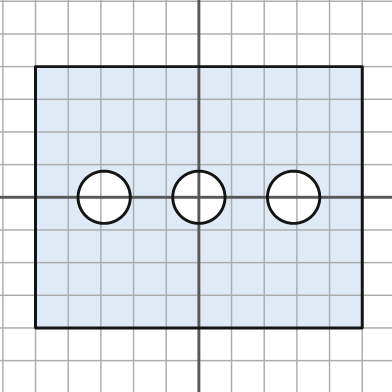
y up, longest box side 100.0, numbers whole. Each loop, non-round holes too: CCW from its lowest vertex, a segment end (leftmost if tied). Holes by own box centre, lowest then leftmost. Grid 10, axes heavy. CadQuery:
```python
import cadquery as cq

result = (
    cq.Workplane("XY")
    .moveTo(-50.0, -40.0)
    .lineTo(50.0, -40.0)
    .lineTo(50.0, 40.0)
    .lineTo(-50.0, 40.0)
    .close()
    .moveTo(-29.0, 0.0)
    .circle(8.0)
    .moveTo(0.0, 0.0)
    .circle(8.0)
    .moveTo(29.0, 0.0)
    .circle(8.0)
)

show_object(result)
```